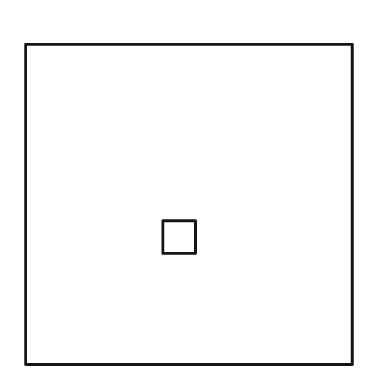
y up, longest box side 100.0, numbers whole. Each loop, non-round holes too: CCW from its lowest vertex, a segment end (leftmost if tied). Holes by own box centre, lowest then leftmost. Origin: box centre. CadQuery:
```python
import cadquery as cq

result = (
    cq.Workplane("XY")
    .moveTo(-50.0, -49.0)
    .lineTo(50.0, -49.0)
    .lineTo(50.0, 49.0)
    .lineTo(-50.0, 49.0)
    .close()
    .moveTo(-8.0, -15.0)
    .lineTo(2.0, -15.0)
    .lineTo(2.0, -5.0)
    .lineTo(-8.0, -5.0)
    .close()
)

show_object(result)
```